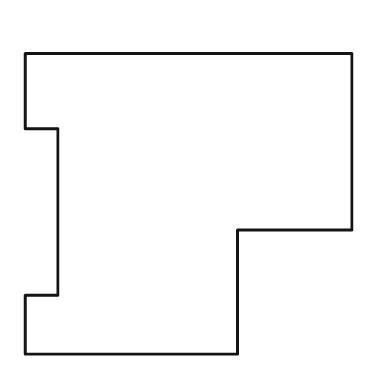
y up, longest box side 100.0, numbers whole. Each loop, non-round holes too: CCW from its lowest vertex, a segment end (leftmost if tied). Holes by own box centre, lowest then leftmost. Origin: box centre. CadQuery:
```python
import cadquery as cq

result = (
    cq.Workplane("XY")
    .moveTo(-50.0, -46.0)
    .lineTo(15.0, -46.0)
    .lineTo(15.0, -8.0)
    .lineTo(50.0, -8.0)
    .lineTo(50.0, 46.0)
    .lineTo(-50.0, 46.0)
    .lineTo(-50.0, 23.0)
    .lineTo(-40.0, 23.0)
    .lineTo(-40.0, -28.0)
    .lineTo(-50.0, -28.0)
    .close()
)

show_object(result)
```